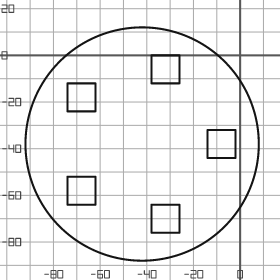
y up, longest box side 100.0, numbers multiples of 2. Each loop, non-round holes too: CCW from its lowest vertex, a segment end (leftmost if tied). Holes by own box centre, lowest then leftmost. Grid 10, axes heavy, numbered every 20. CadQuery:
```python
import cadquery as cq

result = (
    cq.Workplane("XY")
    .moveTo(-42.0, -38.0)
    .circle(50.0)
    .moveTo(-38.0, -76.0)
    .lineTo(-26.0, -76.0)
    .lineTo(-26.0, -64.0)
    .lineTo(-38.0, -64.0)
    .close()
    .moveTo(-74.0, -64.0)
    .lineTo(-62.0, -64.0)
    .lineTo(-62.0, -52.0)
    .lineTo(-74.0, -52.0)
    .close()
    .moveTo(-14.0, -44.0)
    .lineTo(-2.0, -44.0)
    .lineTo(-2.0, -32.0)
    .lineTo(-14.0, -32.0)
    .close()
    .moveTo(-74.0, -24.0)
    .lineTo(-62.0, -24.0)
    .lineTo(-62.0, -12.0)
    .lineTo(-74.0, -12.0)
    .close()
    .moveTo(-38.0, -12.0)
    .lineTo(-26.0, -12.0)
    .lineTo(-26.0, 0.0)
    .lineTo(-38.0, 0.0)
    .close()
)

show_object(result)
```